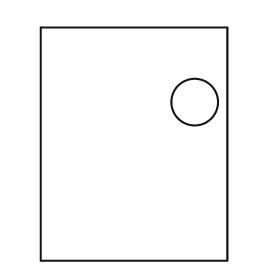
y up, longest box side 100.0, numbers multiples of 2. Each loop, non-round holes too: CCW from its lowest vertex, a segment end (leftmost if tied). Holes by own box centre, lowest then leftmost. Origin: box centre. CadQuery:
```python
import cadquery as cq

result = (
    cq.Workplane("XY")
    .moveTo(-40.0, -50.0)
    .lineTo(40.0, -50.0)
    .lineTo(40.0, 50.0)
    .lineTo(-40.0, 50.0)
    .close()
    .moveTo(26.0, 18.0)
    .circle(10.0)
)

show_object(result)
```